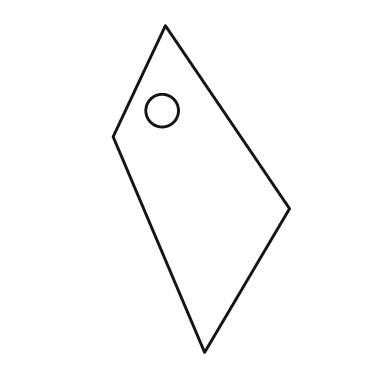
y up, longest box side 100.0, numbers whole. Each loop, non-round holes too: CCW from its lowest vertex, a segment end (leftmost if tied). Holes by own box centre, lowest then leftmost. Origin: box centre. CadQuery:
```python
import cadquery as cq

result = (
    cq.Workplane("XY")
    .moveTo(1.0, -50.0)
    .lineTo(27.0, -6.0)
    .lineTo(-11.0, 50.0)
    .lineTo(-27.0, 16.0)
    .close()
    .moveTo(-12.0, 24.0)
    .circle(5.0)
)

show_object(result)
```